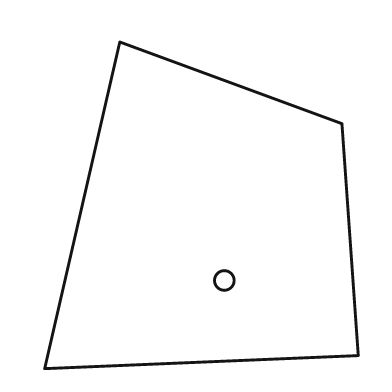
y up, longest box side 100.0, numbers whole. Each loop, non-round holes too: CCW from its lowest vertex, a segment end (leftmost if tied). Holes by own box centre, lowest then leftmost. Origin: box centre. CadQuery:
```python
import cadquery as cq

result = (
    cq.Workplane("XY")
    .moveTo(-48.0, -50.0)
    .lineTo(48.0, -46.0)
    .lineTo(43.0, 25.0)
    .lineTo(-25.0, 50.0)
    .close()
    .moveTo(7.0, -23.0)
    .circle(3.0)
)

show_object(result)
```